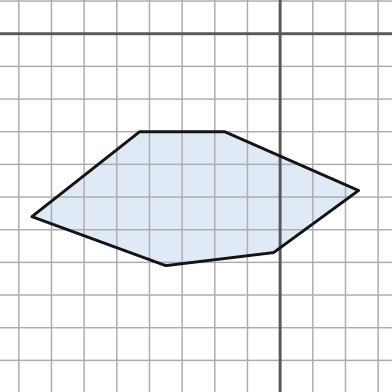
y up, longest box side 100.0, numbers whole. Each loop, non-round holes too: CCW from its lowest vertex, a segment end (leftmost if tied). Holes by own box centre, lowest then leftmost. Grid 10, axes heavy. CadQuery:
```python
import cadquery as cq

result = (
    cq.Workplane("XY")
    .moveTo(-35.0, -71.0)
    .lineTo(-2.0, -67.0)
    .lineTo(24.0, -48.0)
    .lineTo(-17.0, -30.0)
    .lineTo(-43.0, -30.0)
    .lineTo(-76.0, -56.0)
    .close()
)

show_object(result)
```